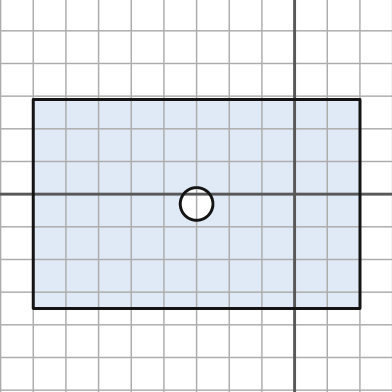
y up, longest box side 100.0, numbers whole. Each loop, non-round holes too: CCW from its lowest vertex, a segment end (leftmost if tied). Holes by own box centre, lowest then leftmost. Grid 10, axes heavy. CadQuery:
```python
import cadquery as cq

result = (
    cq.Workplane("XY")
    .moveTo(-80.0, -35.0)
    .lineTo(20.0, -35.0)
    .lineTo(20.0, 29.0)
    .lineTo(-80.0, 29.0)
    .close()
    .moveTo(-30.0, -3.0)
    .circle(5.0)
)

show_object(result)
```